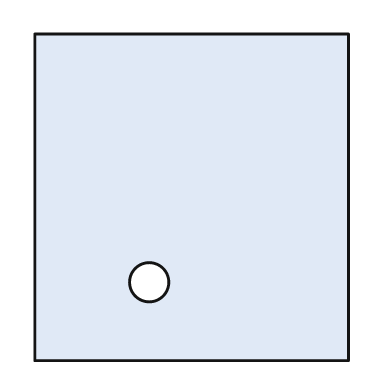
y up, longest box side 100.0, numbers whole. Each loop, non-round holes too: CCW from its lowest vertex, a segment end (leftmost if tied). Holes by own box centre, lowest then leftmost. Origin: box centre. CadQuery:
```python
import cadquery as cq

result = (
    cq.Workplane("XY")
    .moveTo(-48.0, -50.0)
    .lineTo(48.0, -50.0)
    .lineTo(48.0, 50.0)
    .lineTo(-48.0, 50.0)
    .close()
    .moveTo(-13.0, -26.0)
    .circle(6.0)
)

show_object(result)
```